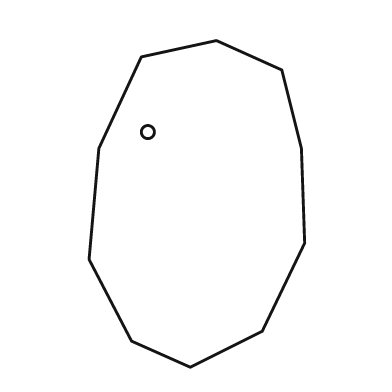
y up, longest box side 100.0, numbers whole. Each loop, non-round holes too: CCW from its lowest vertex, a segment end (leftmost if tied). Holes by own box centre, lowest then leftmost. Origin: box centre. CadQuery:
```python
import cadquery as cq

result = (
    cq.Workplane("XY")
    .moveTo(-2.0, -50.0)
    .lineTo(20.0, -39.0)
    .lineTo(33.0, -12.0)
    .lineTo(32.0, 17.0)
    .lineTo(26.0, 41.0)
    .lineTo(6.0, 50.0)
    .lineTo(-17.0, 45.0)
    .lineTo(-30.0, 17.0)
    .lineTo(-33.0, -17.0)
    .lineTo(-20.0, -42.0)
    .close()
    .moveTo(-15.0, 22.0)
    .circle(2.0)
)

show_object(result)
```